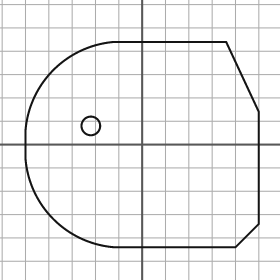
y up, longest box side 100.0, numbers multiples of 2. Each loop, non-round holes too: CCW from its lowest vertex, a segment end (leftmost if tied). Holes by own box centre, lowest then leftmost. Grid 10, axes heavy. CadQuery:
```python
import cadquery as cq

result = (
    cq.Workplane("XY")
    .moveTo(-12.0, -44.0)
    .lineTo(40.0, -44.0)
    .lineTo(50.0, -34.0)
    .lineTo(50.0, 14.0)
    .lineTo(36.0, 44.0)
    .lineTo(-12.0, 44.0)
    .threePointArc((-38.0, 32.0), (-50.0, 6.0))
    .lineTo(-50.0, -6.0)
    .threePointArc((-38.0, -32.0), (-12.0, -44.0))
    .close()
    .moveTo(-22.0, 8.0)
    .circle(4.0)
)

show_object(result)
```